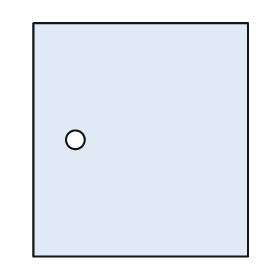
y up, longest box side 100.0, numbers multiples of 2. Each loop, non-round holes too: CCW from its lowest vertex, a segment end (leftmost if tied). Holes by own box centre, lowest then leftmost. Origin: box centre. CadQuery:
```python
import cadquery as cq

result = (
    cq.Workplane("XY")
    .moveTo(-46.0, -50.0)
    .lineTo(46.0, -50.0)
    .lineTo(46.0, 50.0)
    .lineTo(-46.0, 50.0)
    .close()
    .moveTo(-28.0, 0.0)
    .circle(4.0)
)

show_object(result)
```